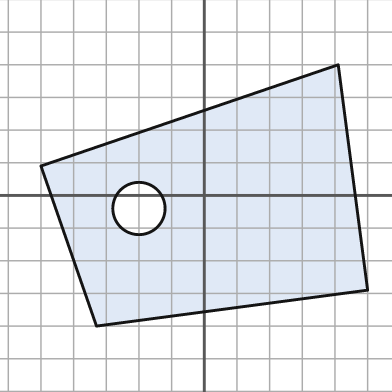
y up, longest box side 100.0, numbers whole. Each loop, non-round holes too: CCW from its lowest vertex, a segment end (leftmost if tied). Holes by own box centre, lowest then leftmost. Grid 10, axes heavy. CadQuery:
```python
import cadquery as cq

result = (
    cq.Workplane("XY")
    .moveTo(-33.0, -40.0)
    .lineTo(50.0, -29.0)
    .lineTo(41.0, 40.0)
    .lineTo(-50.0, 9.0)
    .close()
    .moveTo(-20.0, -4.0)
    .circle(8.0)
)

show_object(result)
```